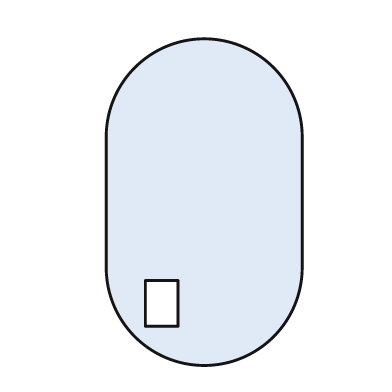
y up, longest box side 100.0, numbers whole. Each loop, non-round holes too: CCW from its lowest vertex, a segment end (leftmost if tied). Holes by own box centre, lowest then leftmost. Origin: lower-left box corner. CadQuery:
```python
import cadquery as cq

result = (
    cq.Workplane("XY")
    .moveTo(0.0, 30.0)
    .threePointArc((30.0, 0.0), (60.0, 30.0))
    .lineTo(60.0, 70.0)
    .threePointArc((30.0, 100.0), (0.0, 70.0))
    .close()
    .moveTo(12.0, 12.0)
    .lineTo(22.0, 12.0)
    .lineTo(22.0, 26.0)
    .lineTo(12.0, 26.0)
    .close()
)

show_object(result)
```